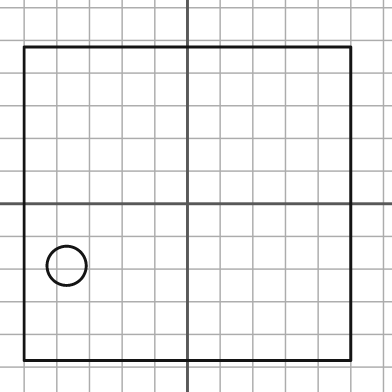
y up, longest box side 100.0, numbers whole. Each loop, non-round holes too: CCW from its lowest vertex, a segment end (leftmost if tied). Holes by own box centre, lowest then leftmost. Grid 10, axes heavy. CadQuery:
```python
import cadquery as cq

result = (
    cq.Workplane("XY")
    .moveTo(-50.0, -48.0)
    .lineTo(50.0, -48.0)
    .lineTo(50.0, 48.0)
    .lineTo(-50.0, 48.0)
    .close()
    .moveTo(-37.0, -19.0)
    .circle(6.0)
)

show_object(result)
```